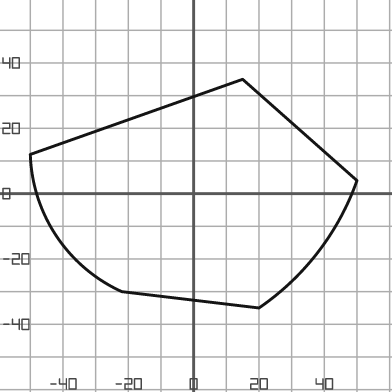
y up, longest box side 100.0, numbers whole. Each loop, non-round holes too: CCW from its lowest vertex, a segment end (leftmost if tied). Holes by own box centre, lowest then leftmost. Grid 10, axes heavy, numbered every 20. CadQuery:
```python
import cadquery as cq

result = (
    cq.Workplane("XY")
    .moveTo(20.0, -35.0)
    .threePointArc((38.0, -18.0), (50.0, 4.0))
    .lineTo(15.0, 35.0)
    .lineTo(-50.0, 12.0)
    .threePointArc((-42.0, -13.0), (-22.0, -30.0))
    .close()
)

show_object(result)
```